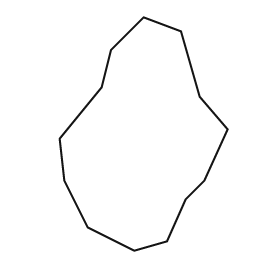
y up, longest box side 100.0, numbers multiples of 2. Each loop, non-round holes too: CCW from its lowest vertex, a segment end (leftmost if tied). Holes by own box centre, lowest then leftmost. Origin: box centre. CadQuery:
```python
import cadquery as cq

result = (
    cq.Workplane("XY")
    .moveTo(-4.0, -50.0)
    .lineTo(10.0, -46.0)
    .lineTo(18.0, -28.0)
    .lineTo(26.0, -20.0)
    .lineTo(36.0, 2.0)
    .lineTo(24.0, 16.0)
    .lineTo(16.0, 44.0)
    .lineTo(0.0, 50.0)
    .lineTo(-14.0, 36.0)
    .lineTo(-18.0, 20.0)
    .lineTo(-36.0, -2.0)
    .lineTo(-34.0, -20.0)
    .lineTo(-24.0, -40.0)
    .close()
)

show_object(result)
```